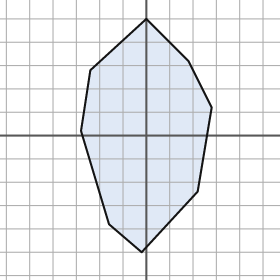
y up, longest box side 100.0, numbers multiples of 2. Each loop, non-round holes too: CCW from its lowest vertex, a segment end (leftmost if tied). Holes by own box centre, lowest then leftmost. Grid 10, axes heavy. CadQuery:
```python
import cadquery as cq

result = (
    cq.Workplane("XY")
    .moveTo(-2.0, -50.0)
    .lineTo(22.0, -24.0)
    .lineTo(28.0, 12.0)
    .lineTo(18.0, 32.0)
    .lineTo(0.0, 50.0)
    .lineTo(-24.0, 28.0)
    .lineTo(-28.0, 2.0)
    .lineTo(-16.0, -38.0)
    .close()
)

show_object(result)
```